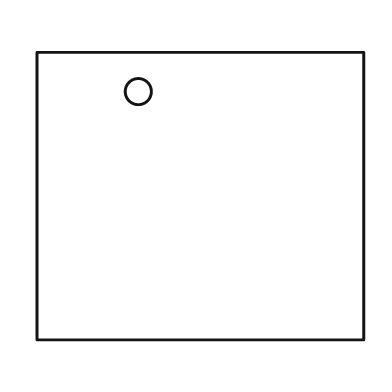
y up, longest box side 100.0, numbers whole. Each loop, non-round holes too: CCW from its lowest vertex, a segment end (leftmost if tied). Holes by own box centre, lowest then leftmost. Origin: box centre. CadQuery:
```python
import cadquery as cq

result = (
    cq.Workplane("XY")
    .moveTo(-50.0, -44.0)
    .lineTo(50.0, -44.0)
    .lineTo(50.0, 44.0)
    .lineTo(-50.0, 44.0)
    .close()
    .moveTo(-19.0, 32.0)
    .circle(4.0)
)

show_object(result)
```